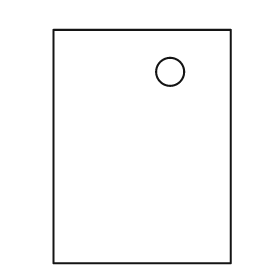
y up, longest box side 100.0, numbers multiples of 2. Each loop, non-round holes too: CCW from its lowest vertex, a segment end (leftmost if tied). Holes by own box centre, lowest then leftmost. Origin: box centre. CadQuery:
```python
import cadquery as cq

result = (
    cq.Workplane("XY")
    .moveTo(-38.0, -50.0)
    .lineTo(38.0, -50.0)
    .lineTo(38.0, 50.0)
    .lineTo(-38.0, 50.0)
    .close()
    .moveTo(12.0, 32.0)
    .circle(6.0)
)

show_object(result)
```